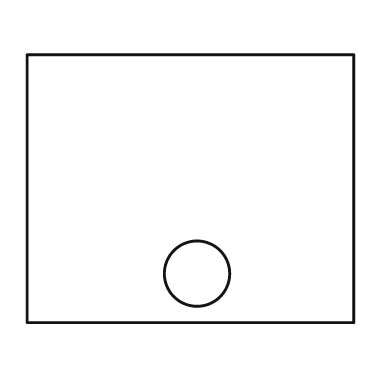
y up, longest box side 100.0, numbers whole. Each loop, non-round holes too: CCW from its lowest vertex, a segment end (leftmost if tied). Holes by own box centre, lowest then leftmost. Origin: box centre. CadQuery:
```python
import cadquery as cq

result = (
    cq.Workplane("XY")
    .moveTo(-50.0, -41.0)
    .lineTo(50.0, -41.0)
    .lineTo(50.0, 41.0)
    .lineTo(-50.0, 41.0)
    .close()
    .moveTo(2.0, -26.0)
    .circle(10.0)
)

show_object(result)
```